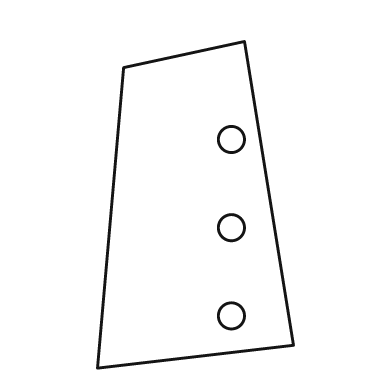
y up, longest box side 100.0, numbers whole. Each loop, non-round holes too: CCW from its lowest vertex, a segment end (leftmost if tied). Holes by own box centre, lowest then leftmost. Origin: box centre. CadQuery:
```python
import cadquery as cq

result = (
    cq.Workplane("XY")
    .moveTo(-30.0, -50.0)
    .lineTo(30.0, -43.0)
    .lineTo(15.0, 50.0)
    .lineTo(-22.0, 42.0)
    .close()
    .moveTo(11.0, -34.0)
    .circle(4.0)
    .moveTo(11.0, -7.0)
    .circle(4.0)
    .moveTo(11.0, 20.0)
    .circle(4.0)
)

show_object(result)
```